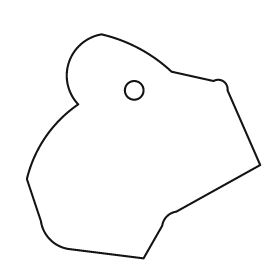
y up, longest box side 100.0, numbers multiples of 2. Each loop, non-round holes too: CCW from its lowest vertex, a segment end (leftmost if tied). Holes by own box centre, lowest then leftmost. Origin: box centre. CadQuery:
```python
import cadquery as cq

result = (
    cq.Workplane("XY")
    .moveTo(0.0, -48.0)
    .lineTo(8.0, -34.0)
    .threePointArc((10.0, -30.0), (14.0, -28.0))
    .lineTo(50.0, -8.0)
    .lineTo(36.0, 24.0)
    .threePointArc((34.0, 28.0), (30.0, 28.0))
    .lineTo(12.0, 32.0)
    .threePointArc((-2.0, 42.0), (-18.0, 48.0))
    .threePointArc((-32.0, 36.0), (-28.0, 18.0))
    .threePointArc((-42.0, 4.0), (-50.0, -14.0))
    .lineTo(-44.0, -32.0)
    .threePointArc((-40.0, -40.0), (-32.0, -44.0))
    .close()
    .moveTo(-4.0, 24.0)
    .circle(4.0)
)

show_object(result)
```